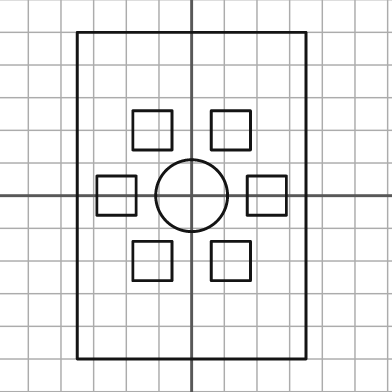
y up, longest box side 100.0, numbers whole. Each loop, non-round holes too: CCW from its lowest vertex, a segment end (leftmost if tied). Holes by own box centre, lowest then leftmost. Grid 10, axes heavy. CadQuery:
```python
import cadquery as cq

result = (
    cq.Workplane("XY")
    .moveTo(-35.0, -50.0)
    .lineTo(35.0, -50.0)
    .lineTo(35.0, 50.0)
    .lineTo(-35.0, 50.0)
    .close()
    .moveTo(-18.0, -26.0)
    .lineTo(-6.0, -26.0)
    .lineTo(-6.0, -14.0)
    .lineTo(-18.0, -14.0)
    .close()
    .moveTo(6.0, -26.0)
    .lineTo(18.0, -26.0)
    .lineTo(18.0, -14.0)
    .lineTo(6.0, -14.0)
    .close()
    .moveTo(-29.0, -6.0)
    .lineTo(-17.0, -6.0)
    .lineTo(-17.0, 6.0)
    .lineTo(-29.0, 6.0)
    .close()
    .moveTo(0.0, 0.0)
    .circle(11.0)
    .moveTo(17.0, -6.0)
    .lineTo(29.0, -6.0)
    .lineTo(29.0, 6.0)
    .lineTo(17.0, 6.0)
    .close()
    .moveTo(-18.0, 14.0)
    .lineTo(-6.0, 14.0)
    .lineTo(-6.0, 26.0)
    .lineTo(-18.0, 26.0)
    .close()
    .moveTo(6.0, 14.0)
    .lineTo(18.0, 14.0)
    .lineTo(18.0, 26.0)
    .lineTo(6.0, 26.0)
    .close()
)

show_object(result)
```